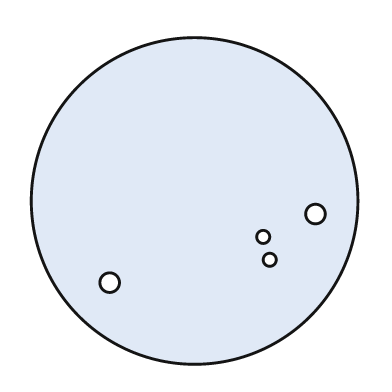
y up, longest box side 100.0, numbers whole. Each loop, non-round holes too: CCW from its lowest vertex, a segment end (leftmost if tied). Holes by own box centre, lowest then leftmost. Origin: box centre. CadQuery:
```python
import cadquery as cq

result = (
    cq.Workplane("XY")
    .moveTo(0.0, 0.0)
    .circle(50.0)
    .moveTo(-26.0, -25.0)
    .circle(3.0)
    .moveTo(23.0, -18.0)
    .circle(2.0)
    .moveTo(21.0, -11.0)
    .circle(2.0)
    .moveTo(37.0, -4.0)
    .circle(3.0)
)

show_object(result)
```